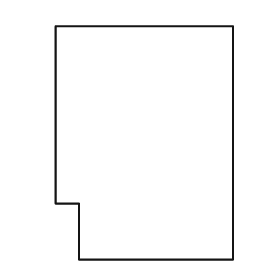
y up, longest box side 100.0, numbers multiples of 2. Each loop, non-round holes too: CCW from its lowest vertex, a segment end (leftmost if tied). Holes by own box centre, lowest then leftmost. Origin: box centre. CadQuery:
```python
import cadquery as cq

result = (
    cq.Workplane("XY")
    .moveTo(-28.0, -50.0)
    .lineTo(38.0, -50.0)
    .lineTo(38.0, 50.0)
    .lineTo(-38.0, 50.0)
    .lineTo(-38.0, -26.0)
    .lineTo(-28.0, -26.0)
    .close()
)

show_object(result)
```